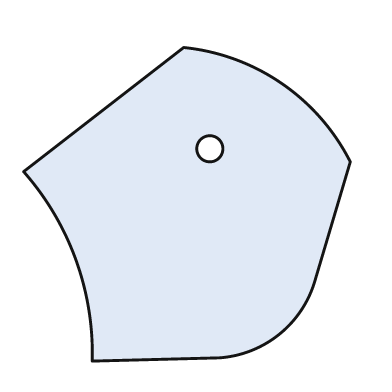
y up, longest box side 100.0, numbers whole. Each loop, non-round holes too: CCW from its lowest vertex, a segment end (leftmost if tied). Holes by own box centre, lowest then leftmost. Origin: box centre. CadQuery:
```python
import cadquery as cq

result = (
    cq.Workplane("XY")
    .moveTo(-29.0, -48.0)
    .lineTo(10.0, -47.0)
    .threePointArc((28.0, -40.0), (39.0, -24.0))
    .lineTo(50.0, 13.0)
    .threePointArc((29.0, 37.0), (-1.0, 48.0))
    .lineTo(-50.0, 10.0)
    .threePointArc((-34.0, -17.0), (-29.0, -48.0))
    .close()
    .moveTo(7.0, 17.0)
    .circle(4.0)
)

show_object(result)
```